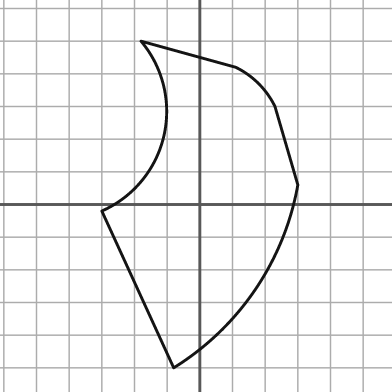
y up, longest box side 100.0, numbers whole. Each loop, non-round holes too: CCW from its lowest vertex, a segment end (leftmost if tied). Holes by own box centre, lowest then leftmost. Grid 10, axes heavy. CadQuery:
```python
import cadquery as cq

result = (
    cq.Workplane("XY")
    .moveTo(-8.0, -50.0)
    .threePointArc((17.0, -26.0), (30.0, 6.0))
    .lineTo(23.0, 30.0)
    .threePointArc((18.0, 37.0), (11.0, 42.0))
    .lineTo(-18.0, 50.0)
    .threePointArc((-11.0, 21.0), (-30.0, -2.0))
    .close()
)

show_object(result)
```